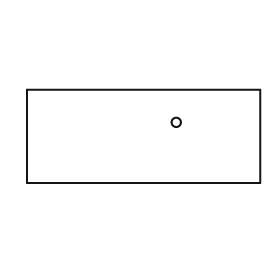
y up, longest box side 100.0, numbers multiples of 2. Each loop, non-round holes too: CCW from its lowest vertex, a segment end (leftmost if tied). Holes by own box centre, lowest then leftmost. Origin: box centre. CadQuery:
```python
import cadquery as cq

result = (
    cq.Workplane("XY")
    .moveTo(-50.0, -20.0)
    .lineTo(50.0, -20.0)
    .lineTo(50.0, 20.0)
    .lineTo(-50.0, 20.0)
    .close()
    .moveTo(14.0, 6.0)
    .circle(2.0)
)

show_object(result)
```